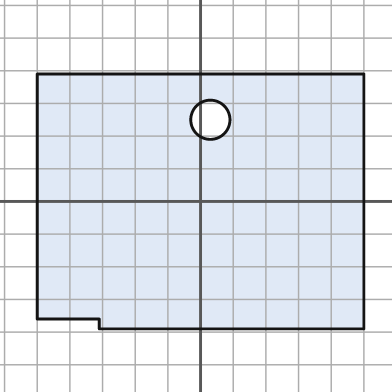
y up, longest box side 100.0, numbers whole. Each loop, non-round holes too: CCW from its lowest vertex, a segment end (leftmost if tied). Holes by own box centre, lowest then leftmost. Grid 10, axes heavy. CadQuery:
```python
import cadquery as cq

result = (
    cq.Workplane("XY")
    .moveTo(-31.0, -39.0)
    .lineTo(50.0, -39.0)
    .lineTo(50.0, 39.0)
    .lineTo(-50.0, 39.0)
    .lineTo(-50.0, -36.0)
    .lineTo(-31.0, -36.0)
    .close()
    .moveTo(3.0, 25.0)
    .circle(6.0)
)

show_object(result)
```